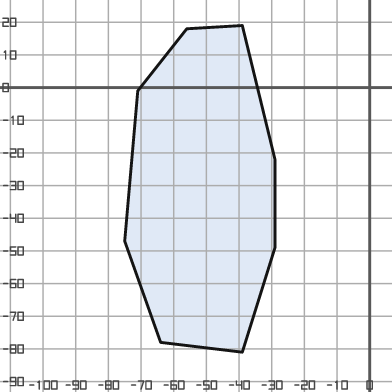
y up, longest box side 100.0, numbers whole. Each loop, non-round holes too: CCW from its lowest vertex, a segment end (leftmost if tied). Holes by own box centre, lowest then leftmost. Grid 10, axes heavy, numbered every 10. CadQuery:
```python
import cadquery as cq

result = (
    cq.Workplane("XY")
    .moveTo(-39.0, -81.0)
    .lineTo(-29.0, -49.0)
    .lineTo(-29.0, -22.0)
    .lineTo(-39.0, 19.0)
    .lineTo(-56.0, 18.0)
    .lineTo(-71.0, -1.0)
    .lineTo(-75.0, -47.0)
    .lineTo(-64.0, -78.0)
    .close()
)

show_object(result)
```